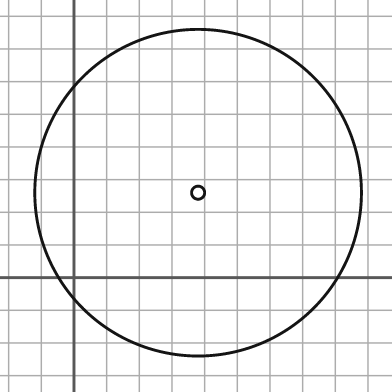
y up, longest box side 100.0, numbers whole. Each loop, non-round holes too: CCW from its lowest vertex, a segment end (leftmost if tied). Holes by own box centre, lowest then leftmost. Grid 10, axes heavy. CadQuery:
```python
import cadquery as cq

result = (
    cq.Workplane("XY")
    .moveTo(38.0, 26.0)
    .circle(50.0)
    .moveTo(38.0, 26.0)
    .circle(2.0)
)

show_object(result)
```